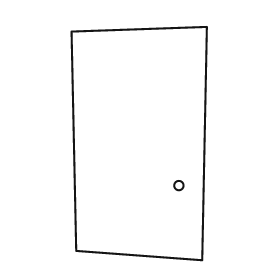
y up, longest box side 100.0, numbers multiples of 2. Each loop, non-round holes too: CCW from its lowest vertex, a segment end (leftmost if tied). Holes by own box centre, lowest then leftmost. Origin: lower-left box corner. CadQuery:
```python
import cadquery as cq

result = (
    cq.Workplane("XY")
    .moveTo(56.0, 0.0)
    .lineTo(58.0, 100.0)
    .lineTo(0.0, 98.0)
    .lineTo(2.0, 4.0)
    .close()
    .moveTo(46.0, 32.0)
    .circle(2.0)
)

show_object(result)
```